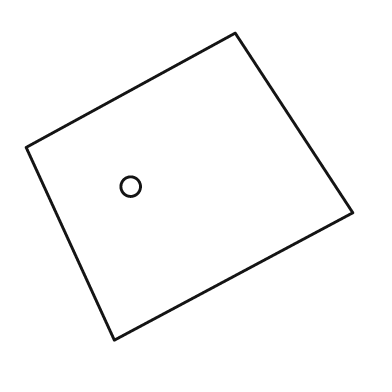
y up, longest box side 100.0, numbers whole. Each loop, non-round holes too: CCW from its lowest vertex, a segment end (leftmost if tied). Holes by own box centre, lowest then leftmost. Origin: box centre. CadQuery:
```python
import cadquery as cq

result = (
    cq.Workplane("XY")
    .moveTo(-23.0, -47.0)
    .lineTo(50.0, -8.0)
    .lineTo(14.0, 47.0)
    .lineTo(-50.0, 12.0)
    .close()
    .moveTo(-18.0, 0.0)
    .circle(3.0)
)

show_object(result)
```